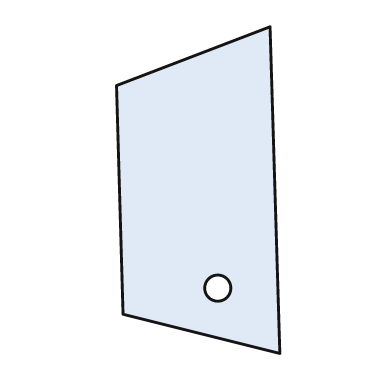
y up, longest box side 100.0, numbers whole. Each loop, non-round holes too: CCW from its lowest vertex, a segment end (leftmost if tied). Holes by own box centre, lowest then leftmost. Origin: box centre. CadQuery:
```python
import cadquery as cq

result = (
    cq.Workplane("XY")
    .moveTo(25.0, -50.0)
    .lineTo(22.0, 50.0)
    .lineTo(-25.0, 32.0)
    .lineTo(-23.0, -38.0)
    .close()
    .moveTo(6.0, -30.0)
    .circle(4.0)
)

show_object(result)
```